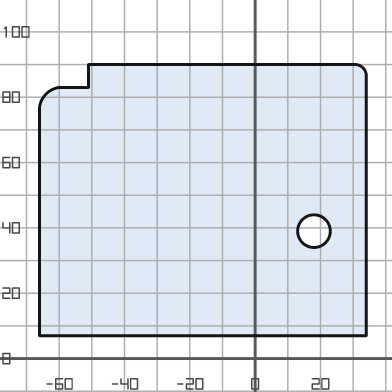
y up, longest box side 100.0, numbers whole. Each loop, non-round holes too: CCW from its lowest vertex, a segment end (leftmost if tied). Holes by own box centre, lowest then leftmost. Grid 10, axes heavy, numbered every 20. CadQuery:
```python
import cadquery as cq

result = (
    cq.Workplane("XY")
    .moveTo(-66.0, 7.0)
    .lineTo(34.0, 7.0)
    .lineTo(34.0, 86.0)
    .threePointArc((33.0, 89.0), (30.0, 90.0))
    .lineTo(-51.0, 90.0)
    .lineTo(-51.0, 83.0)
    .lineTo(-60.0, 83.0)
    .threePointArc((-64.0, 81.0), (-66.0, 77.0))
    .close()
    .moveTo(18.0, 39.0)
    .circle(5.0)
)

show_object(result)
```